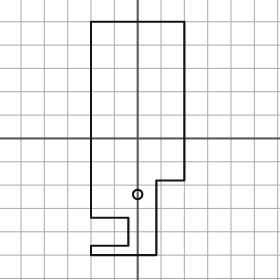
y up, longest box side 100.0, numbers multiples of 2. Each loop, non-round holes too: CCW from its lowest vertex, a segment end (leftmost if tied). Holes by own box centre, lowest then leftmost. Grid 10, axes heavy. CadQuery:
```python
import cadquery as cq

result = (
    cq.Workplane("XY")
    .moveTo(-20.0, -50.0)
    .lineTo(8.0, -50.0)
    .lineTo(8.0, -18.0)
    .lineTo(20.0, -18.0)
    .lineTo(20.0, 50.0)
    .lineTo(-20.0, 50.0)
    .lineTo(-20.0, -34.0)
    .lineTo(-4.0, -34.0)
    .lineTo(-4.0, -46.0)
    .lineTo(-20.0, -46.0)
    .close()
    .moveTo(0.0, -24.0)
    .circle(2.0)
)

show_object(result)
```